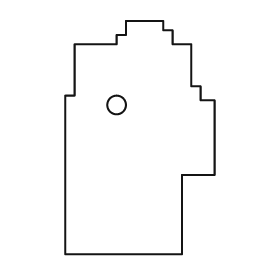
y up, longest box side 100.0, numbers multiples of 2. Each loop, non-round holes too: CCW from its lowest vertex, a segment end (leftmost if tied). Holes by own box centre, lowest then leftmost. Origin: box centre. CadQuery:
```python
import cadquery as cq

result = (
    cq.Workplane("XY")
    .moveTo(-32.0, -50.0)
    .lineTo(18.0, -50.0)
    .lineTo(18.0, -16.0)
    .lineTo(32.0, -16.0)
    .lineTo(32.0, 16.0)
    .lineTo(26.0, 16.0)
    .lineTo(26.0, 22.0)
    .lineTo(22.0, 22.0)
    .lineTo(22.0, 40.0)
    .lineTo(14.0, 40.0)
    .lineTo(14.0, 46.0)
    .lineTo(10.0, 46.0)
    .lineTo(10.0, 50.0)
    .lineTo(-6.0, 50.0)
    .lineTo(-6.0, 44.0)
    .lineTo(-10.0, 44.0)
    .lineTo(-10.0, 40.0)
    .lineTo(-28.0, 40.0)
    .lineTo(-28.0, 18.0)
    .lineTo(-32.0, 18.0)
    .close()
    .moveTo(-10.0, 14.0)
    .circle(4.0)
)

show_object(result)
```